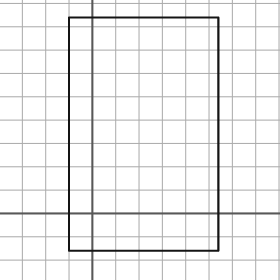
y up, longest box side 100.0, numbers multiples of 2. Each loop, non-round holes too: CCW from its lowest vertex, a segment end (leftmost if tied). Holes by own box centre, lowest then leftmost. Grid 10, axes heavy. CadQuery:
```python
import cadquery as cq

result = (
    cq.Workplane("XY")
    .moveTo(-10.0, -16.0)
    .lineTo(54.0, -16.0)
    .lineTo(54.0, 84.0)
    .lineTo(-10.0, 84.0)
    .close()
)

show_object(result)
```